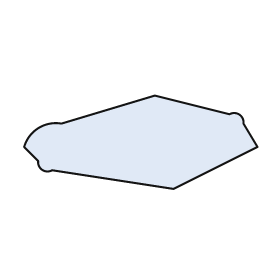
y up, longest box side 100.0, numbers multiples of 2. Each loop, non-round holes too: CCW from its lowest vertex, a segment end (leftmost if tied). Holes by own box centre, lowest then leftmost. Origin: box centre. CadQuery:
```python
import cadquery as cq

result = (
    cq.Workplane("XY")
    .moveTo(14.0, -20.0)
    .lineTo(50.0, -2.0)
    .lineTo(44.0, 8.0)
    .threePointArc((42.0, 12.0), (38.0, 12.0))
    .lineTo(6.0, 20.0)
    .lineTo(-34.0, 8.0)
    .threePointArc((-44.0, 6.0), (-50.0, -2.0))
    .lineTo(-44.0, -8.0)
    .threePointArc((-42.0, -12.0), (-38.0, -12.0))
    .close()
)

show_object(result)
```